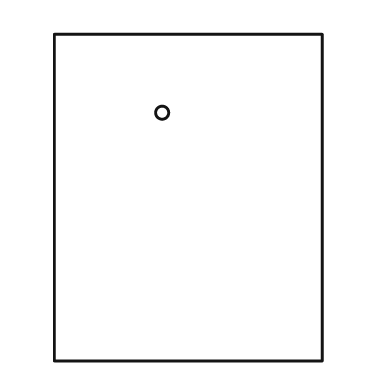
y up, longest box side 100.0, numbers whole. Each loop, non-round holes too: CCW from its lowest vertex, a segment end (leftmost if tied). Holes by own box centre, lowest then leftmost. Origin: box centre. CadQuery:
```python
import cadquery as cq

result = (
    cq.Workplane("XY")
    .moveTo(-41.0, -50.0)
    .lineTo(41.0, -50.0)
    .lineTo(41.0, 50.0)
    .lineTo(-41.0, 50.0)
    .close()
    .moveTo(-8.0, 26.0)
    .circle(2.0)
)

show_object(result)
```